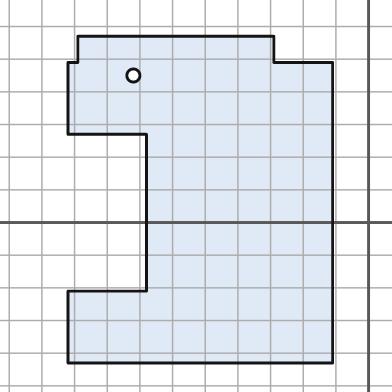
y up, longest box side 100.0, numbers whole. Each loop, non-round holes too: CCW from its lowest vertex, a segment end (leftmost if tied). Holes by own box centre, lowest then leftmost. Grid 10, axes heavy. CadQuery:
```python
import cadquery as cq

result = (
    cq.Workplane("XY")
    .moveTo(-92.0, -43.0)
    .lineTo(-11.0, -43.0)
    .lineTo(-11.0, 49.0)
    .lineTo(-29.0, 49.0)
    .lineTo(-29.0, 57.0)
    .lineTo(-89.0, 57.0)
    .lineTo(-89.0, 49.0)
    .lineTo(-92.0, 49.0)
    .lineTo(-92.0, 27.0)
    .lineTo(-68.0, 27.0)
    .lineTo(-68.0, -21.0)
    .lineTo(-92.0, -21.0)
    .close()
    .moveTo(-72.0, 45.0)
    .circle(2.0)
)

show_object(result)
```